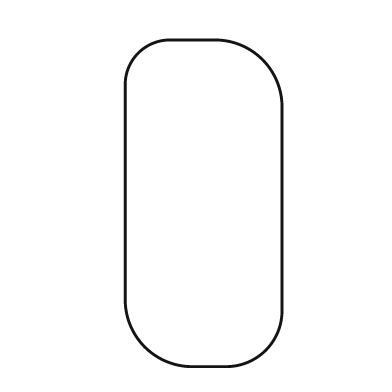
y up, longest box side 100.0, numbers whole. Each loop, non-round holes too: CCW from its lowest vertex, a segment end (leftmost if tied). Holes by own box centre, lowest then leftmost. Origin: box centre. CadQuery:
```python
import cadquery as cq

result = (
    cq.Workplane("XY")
    .moveTo(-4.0, -50.0)
    .lineTo(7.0, -50.0)
    .threePointArc((19.0, -45.0), (24.0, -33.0))
    .lineTo(24.0, 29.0)
    .threePointArc((18.0, 44.0), (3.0, 50.0))
    .lineTo(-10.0, 50.0)
    .threePointArc((-20.0, 46.0), (-24.0, 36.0))
    .lineTo(-24.0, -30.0)
    .threePointArc((-18.0, -44.0), (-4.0, -50.0))
    .close()
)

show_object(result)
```